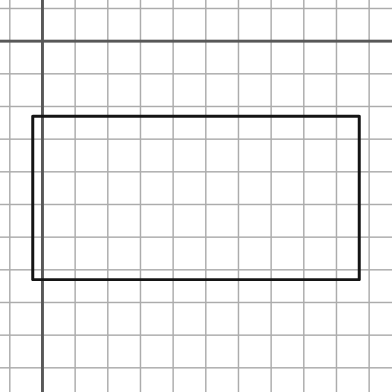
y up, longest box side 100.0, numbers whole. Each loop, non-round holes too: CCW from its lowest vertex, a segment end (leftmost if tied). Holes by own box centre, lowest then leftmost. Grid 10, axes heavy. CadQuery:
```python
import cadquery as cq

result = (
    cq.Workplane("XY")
    .moveTo(-3.0, -73.0)
    .lineTo(97.0, -73.0)
    .lineTo(97.0, -23.0)
    .lineTo(-3.0, -23.0)
    .close()
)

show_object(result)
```